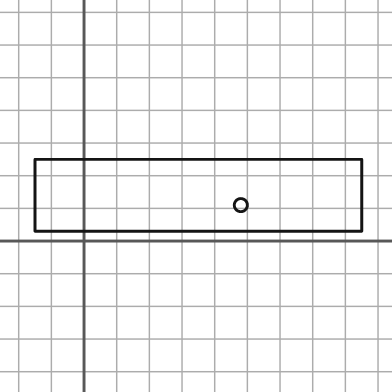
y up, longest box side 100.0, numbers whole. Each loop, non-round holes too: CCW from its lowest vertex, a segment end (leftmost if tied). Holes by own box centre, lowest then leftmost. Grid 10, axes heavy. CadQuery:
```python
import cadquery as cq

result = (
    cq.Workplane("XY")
    .moveTo(-15.0, 3.0)
    .lineTo(85.0, 3.0)
    .lineTo(85.0, 25.0)
    .lineTo(-15.0, 25.0)
    .close()
    .moveTo(48.0, 11.0)
    .circle(2.0)
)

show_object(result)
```